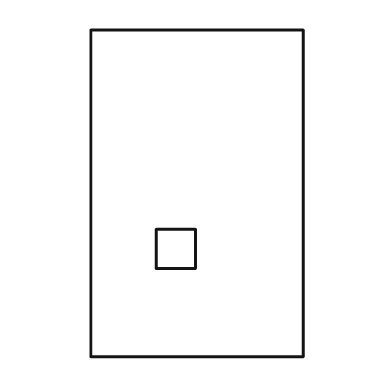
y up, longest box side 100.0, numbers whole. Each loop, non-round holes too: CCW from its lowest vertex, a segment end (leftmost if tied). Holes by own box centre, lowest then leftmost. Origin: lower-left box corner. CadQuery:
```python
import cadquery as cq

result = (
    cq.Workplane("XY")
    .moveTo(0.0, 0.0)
    .lineTo(65.0, 0.0)
    .lineTo(65.0, 100.0)
    .lineTo(0.0, 100.0)
    .close()
    .moveTo(20.0, 27.0)
    .lineTo(32.0, 27.0)
    .lineTo(32.0, 39.0)
    .lineTo(20.0, 39.0)
    .close()
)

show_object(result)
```